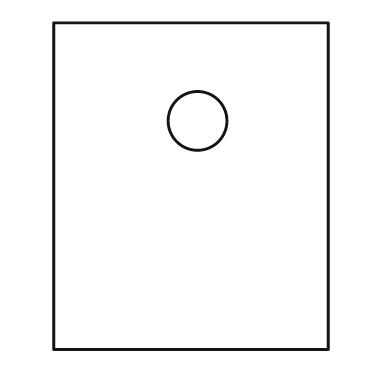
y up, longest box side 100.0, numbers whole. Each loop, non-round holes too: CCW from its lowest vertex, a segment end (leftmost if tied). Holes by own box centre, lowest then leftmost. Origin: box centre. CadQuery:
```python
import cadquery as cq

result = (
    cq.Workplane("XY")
    .moveTo(-42.0, -50.0)
    .lineTo(42.0, -50.0)
    .lineTo(42.0, 50.0)
    .lineTo(-42.0, 50.0)
    .close()
    .moveTo(2.0, 20.0)
    .circle(9.0)
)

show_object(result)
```